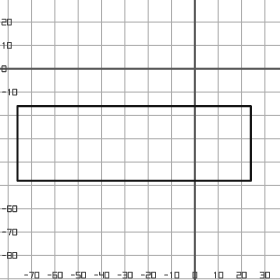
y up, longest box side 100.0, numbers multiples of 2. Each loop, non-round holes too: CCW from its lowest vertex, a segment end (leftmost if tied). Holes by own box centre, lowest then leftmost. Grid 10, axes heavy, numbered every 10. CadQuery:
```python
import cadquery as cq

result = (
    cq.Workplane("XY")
    .moveTo(-76.0, -48.0)
    .lineTo(24.0, -48.0)
    .lineTo(24.0, -16.0)
    .lineTo(-76.0, -16.0)
    .close()
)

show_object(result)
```